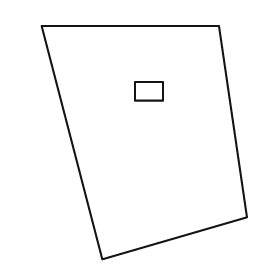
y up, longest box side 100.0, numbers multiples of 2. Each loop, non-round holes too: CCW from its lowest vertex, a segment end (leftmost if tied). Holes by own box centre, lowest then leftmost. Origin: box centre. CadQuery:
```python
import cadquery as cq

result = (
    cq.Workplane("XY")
    .moveTo(-18.0, -50.0)
    .lineTo(44.0, -32.0)
    .lineTo(32.0, 50.0)
    .lineTo(-44.0, 50.0)
    .close()
    .moveTo(-4.0, 18.0)
    .lineTo(8.0, 18.0)
    .lineTo(8.0, 26.0)
    .lineTo(-4.0, 26.0)
    .close()
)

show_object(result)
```